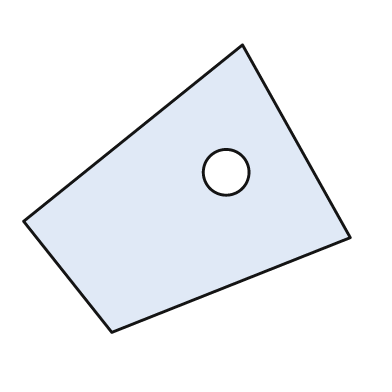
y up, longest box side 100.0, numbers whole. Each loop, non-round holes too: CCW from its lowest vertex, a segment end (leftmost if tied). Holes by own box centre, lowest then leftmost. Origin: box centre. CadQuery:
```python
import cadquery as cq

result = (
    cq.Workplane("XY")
    .moveTo(-23.0, -44.0)
    .lineTo(50.0, -15.0)
    .lineTo(17.0, 44.0)
    .lineTo(-50.0, -10.0)
    .close()
    .moveTo(12.0, 5.0)
    .circle(7.0)
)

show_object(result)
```